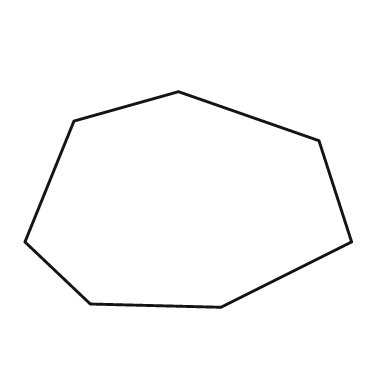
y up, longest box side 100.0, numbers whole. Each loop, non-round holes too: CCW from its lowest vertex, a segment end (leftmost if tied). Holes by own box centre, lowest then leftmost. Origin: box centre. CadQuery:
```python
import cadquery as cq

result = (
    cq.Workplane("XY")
    .moveTo(10.0, -33.0)
    .lineTo(50.0, -13.0)
    .lineTo(40.0, 18.0)
    .lineTo(-3.0, 33.0)
    .lineTo(-35.0, 24.0)
    .lineTo(-50.0, -13.0)
    .lineTo(-30.0, -32.0)
    .close()
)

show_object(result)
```